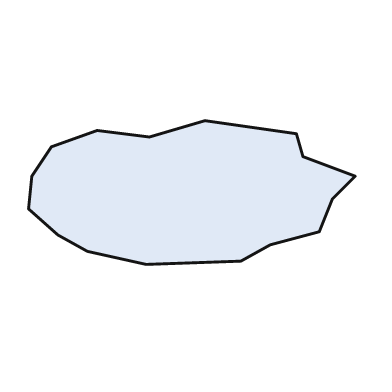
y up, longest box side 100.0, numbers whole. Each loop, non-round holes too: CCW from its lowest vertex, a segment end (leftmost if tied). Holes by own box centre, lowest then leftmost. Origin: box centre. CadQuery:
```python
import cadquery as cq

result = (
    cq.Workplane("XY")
    .moveTo(-14.0, -22.0)
    .lineTo(15.0, -21.0)
    .lineTo(24.0, -16.0)
    .lineTo(39.0, -12.0)
    .lineTo(43.0, -2.0)
    .lineTo(50.0, 5.0)
    .lineTo(34.0, 11.0)
    .lineTo(32.0, 18.0)
    .lineTo(4.0, 22.0)
    .lineTo(-13.0, 17.0)
    .lineTo(-29.0, 19.0)
    .lineTo(-43.0, 14.0)
    .lineTo(-49.0, 5.0)
    .lineTo(-50.0, -5.0)
    .lineTo(-41.0, -13.0)
    .lineTo(-32.0, -18.0)
    .close()
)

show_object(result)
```